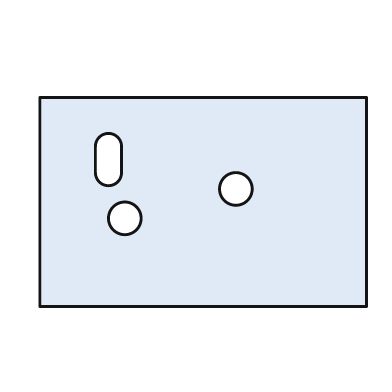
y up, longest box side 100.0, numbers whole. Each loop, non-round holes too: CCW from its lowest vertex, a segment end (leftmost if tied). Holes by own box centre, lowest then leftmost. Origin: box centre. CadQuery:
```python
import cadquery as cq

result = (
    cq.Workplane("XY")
    .moveTo(-50.0, -32.0)
    .lineTo(50.0, -32.0)
    .lineTo(50.0, 32.0)
    .lineTo(-50.0, 32.0)
    .close()
    .moveTo(-24.0, -5.0)
    .circle(5.0)
    .moveTo(10.0, 4.0)
    .circle(5.0)
    .moveTo(-33.0, 9.0)
    .threePointArc((-29.0, 5.0), (-25.0, 9.0))
    .lineTo(-25.0, 17.0)
    .threePointArc((-29.0, 21.0), (-33.0, 17.0))
    .close()
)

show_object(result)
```